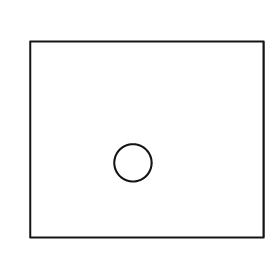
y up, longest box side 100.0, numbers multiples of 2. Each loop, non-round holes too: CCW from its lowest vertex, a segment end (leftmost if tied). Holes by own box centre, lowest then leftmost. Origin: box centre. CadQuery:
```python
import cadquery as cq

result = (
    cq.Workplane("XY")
    .moveTo(-50.0, -42.0)
    .lineTo(50.0, -42.0)
    .lineTo(50.0, 42.0)
    .lineTo(-50.0, 42.0)
    .close()
    .moveTo(-6.0, -10.0)
    .circle(8.0)
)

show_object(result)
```